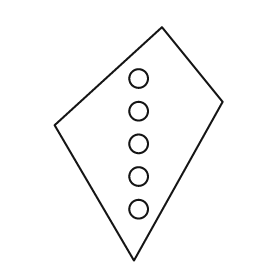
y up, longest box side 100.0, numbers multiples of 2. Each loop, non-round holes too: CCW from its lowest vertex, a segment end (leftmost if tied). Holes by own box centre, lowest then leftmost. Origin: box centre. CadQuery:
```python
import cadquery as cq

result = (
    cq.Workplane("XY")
    .moveTo(-2.0, -50.0)
    .lineTo(36.0, 18.0)
    .lineTo(10.0, 50.0)
    .lineTo(-36.0, 8.0)
    .close()
    .moveTo(0.0, -28.0)
    .circle(4.0)
    .moveTo(0.0, -14.0)
    .circle(4.0)
    .moveTo(0.0, 0.0)
    .circle(4.0)
    .moveTo(0.0, 14.0)
    .circle(4.0)
    .moveTo(0.0, 28.0)
    .circle(4.0)
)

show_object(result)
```